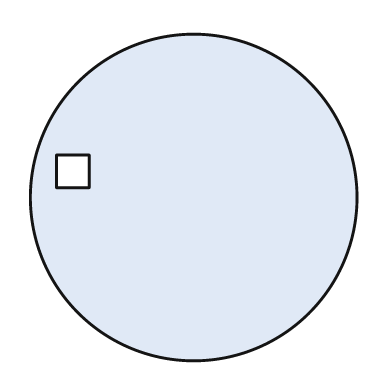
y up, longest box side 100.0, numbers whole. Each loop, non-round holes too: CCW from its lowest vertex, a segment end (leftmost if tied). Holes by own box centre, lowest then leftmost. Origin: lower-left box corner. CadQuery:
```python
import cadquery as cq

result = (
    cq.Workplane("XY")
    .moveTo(50.0, 50.0)
    .circle(50.0)
    .moveTo(8.0, 53.0)
    .lineTo(18.0, 53.0)
    .lineTo(18.0, 63.0)
    .lineTo(8.0, 63.0)
    .close()
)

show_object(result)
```